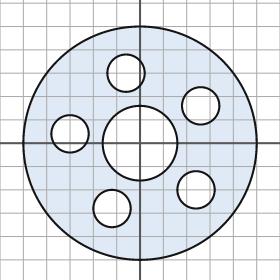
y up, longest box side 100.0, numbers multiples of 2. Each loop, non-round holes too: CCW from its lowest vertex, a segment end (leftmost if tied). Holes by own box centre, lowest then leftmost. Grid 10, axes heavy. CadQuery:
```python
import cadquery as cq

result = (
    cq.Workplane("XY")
    .moveTo(0.0, 0.0)
    .circle(50.0)
    .moveTo(-12.0, -28.0)
    .circle(8.0)
    .moveTo(24.0, -20.0)
    .circle(8.0)
    .moveTo(0.0, 0.0)
    .circle(16.0)
    .moveTo(-30.0, 4.0)
    .circle(8.0)
    .moveTo(26.0, 16.0)
    .circle(8.0)
    .moveTo(-6.0, 30.0)
    .circle(8.0)
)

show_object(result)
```